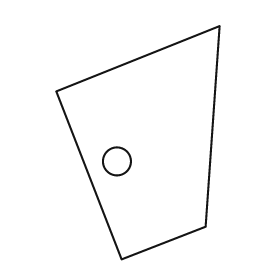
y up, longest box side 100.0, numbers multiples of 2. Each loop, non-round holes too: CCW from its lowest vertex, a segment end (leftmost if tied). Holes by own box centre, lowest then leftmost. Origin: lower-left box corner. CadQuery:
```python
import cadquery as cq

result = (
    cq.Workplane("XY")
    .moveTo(28.0, 0.0)
    .lineTo(64.0, 14.0)
    .lineTo(70.0, 100.0)
    .lineTo(0.0, 72.0)
    .close()
    .moveTo(26.0, 42.0)
    .circle(6.0)
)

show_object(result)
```